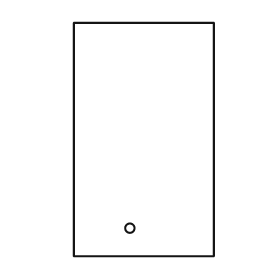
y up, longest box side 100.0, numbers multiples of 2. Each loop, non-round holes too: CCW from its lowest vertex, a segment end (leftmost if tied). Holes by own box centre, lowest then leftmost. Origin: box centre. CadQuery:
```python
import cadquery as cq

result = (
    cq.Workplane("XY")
    .moveTo(-30.0, -50.0)
    .lineTo(30.0, -50.0)
    .lineTo(30.0, 50.0)
    .lineTo(-30.0, 50.0)
    .close()
    .moveTo(-6.0, -38.0)
    .circle(2.0)
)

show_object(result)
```